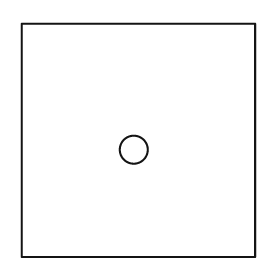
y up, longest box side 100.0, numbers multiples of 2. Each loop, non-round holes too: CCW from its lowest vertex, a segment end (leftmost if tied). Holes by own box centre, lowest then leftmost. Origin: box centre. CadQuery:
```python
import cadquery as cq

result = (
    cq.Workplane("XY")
    .moveTo(-50.0, -50.0)
    .lineTo(50.0, -50.0)
    .lineTo(50.0, 50.0)
    .lineTo(-50.0, 50.0)
    .close()
    .moveTo(-2.0, -4.0)
    .circle(6.0)
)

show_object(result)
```